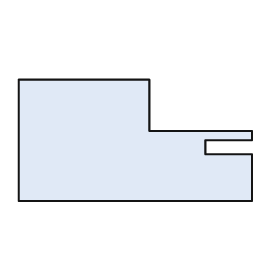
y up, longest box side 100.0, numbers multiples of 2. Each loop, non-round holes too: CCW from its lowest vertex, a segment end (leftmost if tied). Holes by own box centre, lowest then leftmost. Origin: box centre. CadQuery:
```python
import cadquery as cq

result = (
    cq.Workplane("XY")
    .moveTo(-50.0, -26.0)
    .lineTo(50.0, -26.0)
    .lineTo(50.0, -6.0)
    .lineTo(30.0, -6.0)
    .lineTo(30.0, 0.0)
    .lineTo(50.0, 0.0)
    .lineTo(50.0, 4.0)
    .lineTo(6.0, 4.0)
    .lineTo(6.0, 26.0)
    .lineTo(-50.0, 26.0)
    .close()
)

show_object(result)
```